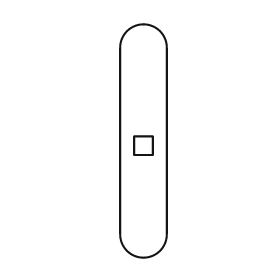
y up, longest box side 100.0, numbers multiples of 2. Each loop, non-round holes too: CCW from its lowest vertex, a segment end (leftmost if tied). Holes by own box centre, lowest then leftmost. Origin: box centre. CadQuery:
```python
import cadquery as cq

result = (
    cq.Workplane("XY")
    .moveTo(-10.0, -40.0)
    .threePointArc((0.0, -50.0), (10.0, -40.0))
    .lineTo(10.0, 40.0)
    .threePointArc((0.0, 50.0), (-10.0, 40.0))
    .close()
    .moveTo(-4.0, -6.0)
    .lineTo(4.0, -6.0)
    .lineTo(4.0, 2.0)
    .lineTo(-4.0, 2.0)
    .close()
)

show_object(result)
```